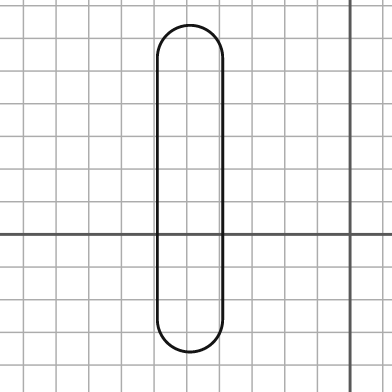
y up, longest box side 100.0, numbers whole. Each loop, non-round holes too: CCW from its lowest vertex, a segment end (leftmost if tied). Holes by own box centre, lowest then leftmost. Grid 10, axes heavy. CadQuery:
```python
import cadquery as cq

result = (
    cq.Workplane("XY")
    .moveTo(-59.0, -26.0)
    .threePointArc((-49.0, -36.0), (-39.0, -26.0))
    .lineTo(-39.0, 54.0)
    .threePointArc((-49.0, 64.0), (-59.0, 54.0))
    .close()
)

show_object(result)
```